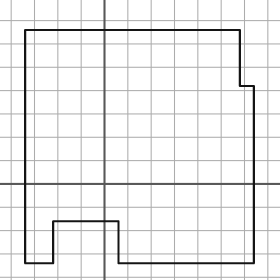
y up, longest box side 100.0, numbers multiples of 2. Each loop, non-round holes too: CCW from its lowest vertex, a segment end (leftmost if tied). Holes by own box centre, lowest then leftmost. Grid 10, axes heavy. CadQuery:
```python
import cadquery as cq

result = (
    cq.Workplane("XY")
    .moveTo(-34.0, -34.0)
    .lineTo(-22.0, -34.0)
    .lineTo(-22.0, -16.0)
    .lineTo(6.0, -16.0)
    .lineTo(6.0, -34.0)
    .lineTo(64.0, -34.0)
    .lineTo(64.0, 42.0)
    .lineTo(58.0, 42.0)
    .lineTo(58.0, 66.0)
    .lineTo(-34.0, 66.0)
    .close()
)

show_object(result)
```